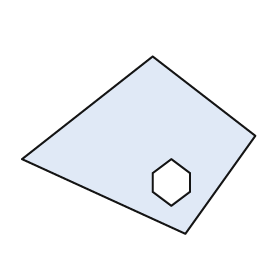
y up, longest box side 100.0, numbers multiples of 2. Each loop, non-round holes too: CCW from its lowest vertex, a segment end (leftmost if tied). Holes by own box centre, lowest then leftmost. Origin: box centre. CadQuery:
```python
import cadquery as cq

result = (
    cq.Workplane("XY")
    .moveTo(20.0, -38.0)
    .lineTo(50.0, 4.0)
    .lineTo(6.0, 38.0)
    .lineTo(-50.0, -6.0)
    .close()
    .moveTo(14.0, -26.0)
    .lineTo(22.0, -20.0)
    .lineTo(22.0, -12.0)
    .lineTo(14.0, -6.0)
    .lineTo(6.0, -12.0)
    .lineTo(6.0, -20.0)
    .close()
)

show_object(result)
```